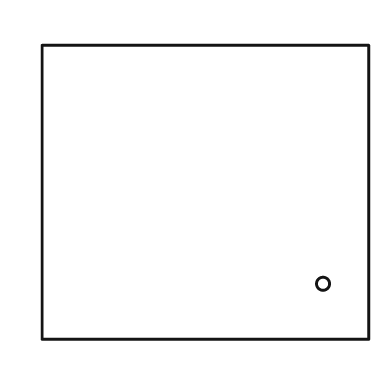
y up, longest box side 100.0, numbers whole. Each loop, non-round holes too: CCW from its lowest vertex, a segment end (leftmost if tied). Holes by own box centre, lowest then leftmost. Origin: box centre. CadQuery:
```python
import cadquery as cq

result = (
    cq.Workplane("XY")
    .moveTo(-50.0, -45.0)
    .lineTo(50.0, -45.0)
    .lineTo(50.0, 45.0)
    .lineTo(-50.0, 45.0)
    .close()
    .moveTo(36.0, -28.0)
    .circle(2.0)
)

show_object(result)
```